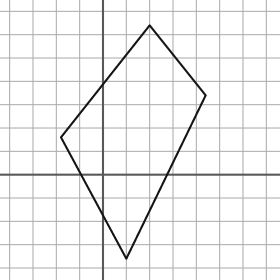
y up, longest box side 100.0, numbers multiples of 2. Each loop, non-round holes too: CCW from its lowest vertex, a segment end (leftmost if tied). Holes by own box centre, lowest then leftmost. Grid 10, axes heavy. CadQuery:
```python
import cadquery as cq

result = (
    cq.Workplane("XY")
    .moveTo(10.0, -36.0)
    .lineTo(44.0, 34.0)
    .lineTo(20.0, 64.0)
    .lineTo(-18.0, 16.0)
    .close()
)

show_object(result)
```